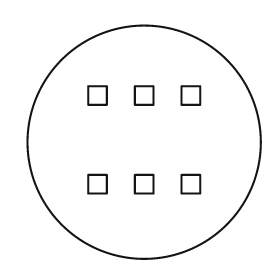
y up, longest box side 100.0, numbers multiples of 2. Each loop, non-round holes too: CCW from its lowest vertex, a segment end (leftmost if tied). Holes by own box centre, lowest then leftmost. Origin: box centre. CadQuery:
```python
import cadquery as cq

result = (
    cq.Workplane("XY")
    .moveTo(0.0, 0.0)
    .circle(50.0)
    .moveTo(-24.0, -22.0)
    .lineTo(-16.0, -22.0)
    .lineTo(-16.0, -14.0)
    .lineTo(-24.0, -14.0)
    .close()
    .moveTo(-4.0, -22.0)
    .lineTo(4.0, -22.0)
    .lineTo(4.0, -14.0)
    .lineTo(-4.0, -14.0)
    .close()
    .moveTo(16.0, -22.0)
    .lineTo(24.0, -22.0)
    .lineTo(24.0, -14.0)
    .lineTo(16.0, -14.0)
    .close()
    .moveTo(-24.0, 16.0)
    .lineTo(-16.0, 16.0)
    .lineTo(-16.0, 24.0)
    .lineTo(-24.0, 24.0)
    .close()
    .moveTo(-4.0, 16.0)
    .lineTo(4.0, 16.0)
    .lineTo(4.0, 24.0)
    .lineTo(-4.0, 24.0)
    .close()
    .moveTo(16.0, 16.0)
    .lineTo(24.0, 16.0)
    .lineTo(24.0, 24.0)
    .lineTo(16.0, 24.0)
    .close()
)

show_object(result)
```